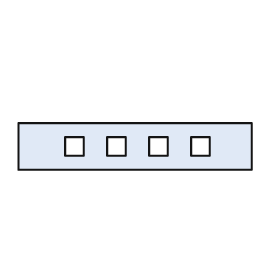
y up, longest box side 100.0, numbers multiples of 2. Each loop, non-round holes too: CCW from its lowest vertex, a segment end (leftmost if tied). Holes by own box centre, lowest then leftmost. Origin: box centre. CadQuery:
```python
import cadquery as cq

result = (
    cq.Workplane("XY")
    .moveTo(-50.0, -10.0)
    .lineTo(50.0, -10.0)
    .lineTo(50.0, 10.0)
    .lineTo(-50.0, 10.0)
    .close()
    .moveTo(-30.0, -4.0)
    .lineTo(-22.0, -4.0)
    .lineTo(-22.0, 4.0)
    .lineTo(-30.0, 4.0)
    .close()
    .moveTo(-12.0, -4.0)
    .lineTo(-4.0, -4.0)
    .lineTo(-4.0, 4.0)
    .lineTo(-12.0, 4.0)
    .close()
    .moveTo(6.0, -4.0)
    .lineTo(14.0, -4.0)
    .lineTo(14.0, 4.0)
    .lineTo(6.0, 4.0)
    .close()
    .moveTo(24.0, -4.0)
    .lineTo(32.0, -4.0)
    .lineTo(32.0, 4.0)
    .lineTo(24.0, 4.0)
    .close()
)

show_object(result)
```